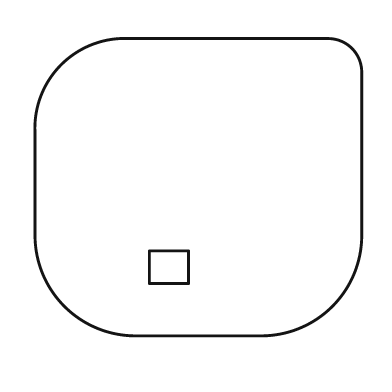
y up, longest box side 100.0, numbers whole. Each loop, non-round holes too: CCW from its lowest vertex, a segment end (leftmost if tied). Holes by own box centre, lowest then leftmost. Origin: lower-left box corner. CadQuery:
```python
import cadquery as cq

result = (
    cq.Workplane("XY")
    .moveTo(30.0, 0.0)
    .lineTo(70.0, 0.0)
    .threePointArc((91.0, 9.0), (100.0, 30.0))
    .lineTo(100.0, 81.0)
    .threePointArc((97.0, 88.0), (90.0, 91.0))
    .lineTo(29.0, 91.0)
    .threePointArc((8.0, 83.0), (0.0, 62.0))
    .lineTo(0.0, 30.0)
    .threePointArc((9.0, 9.0), (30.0, 0.0))
    .close()
    .moveTo(35.0, 16.0)
    .lineTo(47.0, 16.0)
    .lineTo(47.0, 26.0)
    .lineTo(35.0, 26.0)
    .close()
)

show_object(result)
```